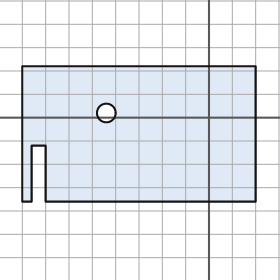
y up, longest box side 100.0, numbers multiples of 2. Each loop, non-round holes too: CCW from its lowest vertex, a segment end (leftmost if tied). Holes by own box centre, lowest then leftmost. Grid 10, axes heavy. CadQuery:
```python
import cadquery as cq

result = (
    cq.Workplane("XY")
    .moveTo(-80.0, -36.0)
    .lineTo(-76.0, -36.0)
    .lineTo(-76.0, -12.0)
    .lineTo(-70.0, -12.0)
    .lineTo(-70.0, -36.0)
    .lineTo(20.0, -36.0)
    .lineTo(20.0, 22.0)
    .lineTo(-80.0, 22.0)
    .close()
    .moveTo(-44.0, 2.0)
    .circle(4.0)
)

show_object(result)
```